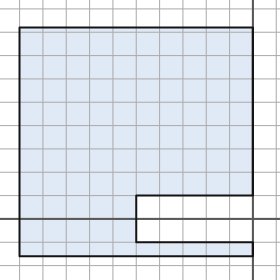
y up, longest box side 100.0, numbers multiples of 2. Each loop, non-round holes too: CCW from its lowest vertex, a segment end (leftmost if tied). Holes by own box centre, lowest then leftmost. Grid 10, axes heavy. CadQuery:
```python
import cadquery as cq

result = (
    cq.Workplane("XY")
    .moveTo(-100.0, -16.0)
    .lineTo(0.0, -16.0)
    .lineTo(0.0, -10.0)
    .lineTo(-50.0, -10.0)
    .lineTo(-50.0, 10.0)
    .lineTo(0.0, 10.0)
    .lineTo(0.0, 82.0)
    .lineTo(-100.0, 82.0)
    .close()
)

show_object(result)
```